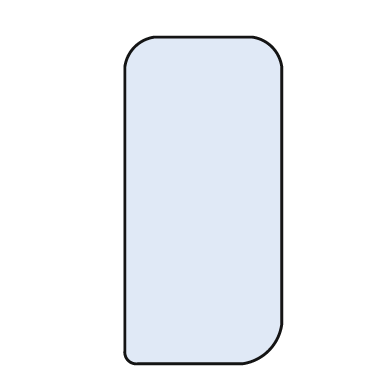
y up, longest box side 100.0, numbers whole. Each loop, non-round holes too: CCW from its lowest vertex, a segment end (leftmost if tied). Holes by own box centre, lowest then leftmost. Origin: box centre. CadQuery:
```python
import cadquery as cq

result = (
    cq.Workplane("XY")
    .moveTo(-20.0, -50.0)
    .lineTo(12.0, -50.0)
    .threePointArc((20.0, -46.0), (24.0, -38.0))
    .lineTo(24.0, 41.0)
    .threePointArc((21.0, 47.0), (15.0, 50.0))
    .lineTo(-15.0, 50.0)
    .threePointArc((-21.0, 47.0), (-24.0, 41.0))
    .lineTo(-24.0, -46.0)
    .threePointArc((-23.0, -49.0), (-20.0, -50.0))
    .close()
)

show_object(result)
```